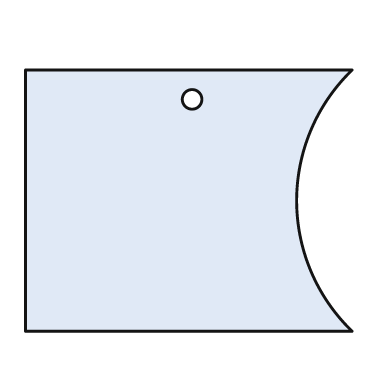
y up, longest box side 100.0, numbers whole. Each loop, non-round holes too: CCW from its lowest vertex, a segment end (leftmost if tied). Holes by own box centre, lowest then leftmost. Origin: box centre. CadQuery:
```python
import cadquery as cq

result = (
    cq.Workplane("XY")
    .moveTo(-50.0, -40.0)
    .lineTo(50.0, -40.0)
    .threePointArc((33.0, 0.0), (50.0, 40.0))
    .lineTo(-50.0, 40.0)
    .close()
    .moveTo(1.0, 31.0)
    .circle(3.0)
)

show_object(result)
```